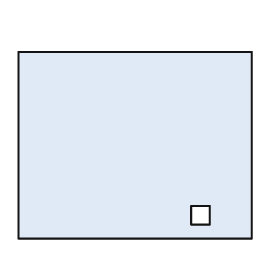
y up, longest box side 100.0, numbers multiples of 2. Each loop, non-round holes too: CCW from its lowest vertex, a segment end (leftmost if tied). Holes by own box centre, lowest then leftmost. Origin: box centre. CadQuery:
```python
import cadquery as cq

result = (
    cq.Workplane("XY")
    .moveTo(-50.0, -40.0)
    .lineTo(50.0, -40.0)
    .lineTo(50.0, 40.0)
    .lineTo(-50.0, 40.0)
    .close()
    .moveTo(24.0, -34.0)
    .lineTo(32.0, -34.0)
    .lineTo(32.0, -26.0)
    .lineTo(24.0, -26.0)
    .close()
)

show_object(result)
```